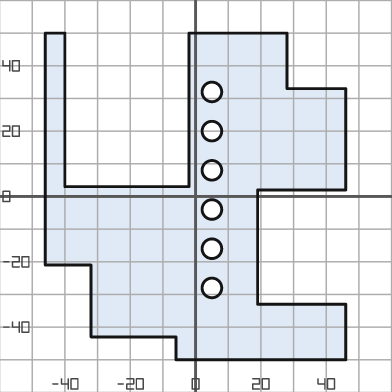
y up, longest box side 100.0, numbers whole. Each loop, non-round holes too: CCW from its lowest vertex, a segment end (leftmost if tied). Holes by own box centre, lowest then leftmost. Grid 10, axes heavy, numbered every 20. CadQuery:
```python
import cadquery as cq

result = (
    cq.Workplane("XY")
    .moveTo(-6.0, -50.0)
    .lineTo(46.0, -50.0)
    .lineTo(46.0, -33.0)
    .lineTo(19.0, -33.0)
    .lineTo(19.0, 2.0)
    .lineTo(46.0, 2.0)
    .lineTo(46.0, 33.0)
    .lineTo(28.0, 33.0)
    .lineTo(28.0, 50.0)
    .lineTo(-2.0, 50.0)
    .lineTo(-2.0, 3.0)
    .lineTo(-40.0, 3.0)
    .lineTo(-40.0, 50.0)
    .lineTo(-46.0, 50.0)
    .lineTo(-46.0, -21.0)
    .lineTo(-32.0, -21.0)
    .lineTo(-32.0, -43.0)
    .lineTo(-6.0, -43.0)
    .close()
    .moveTo(5.0, -28.0)
    .circle(3.0)
    .moveTo(5.0, -16.0)
    .circle(3.0)
    .moveTo(5.0, -4.0)
    .circle(3.0)
    .moveTo(5.0, 8.0)
    .circle(3.0)
    .moveTo(5.0, 20.0)
    .circle(3.0)
    .moveTo(5.0, 32.0)
    .circle(3.0)
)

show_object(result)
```